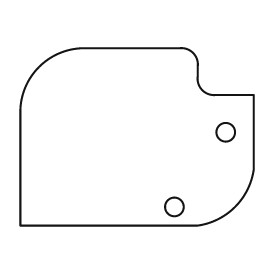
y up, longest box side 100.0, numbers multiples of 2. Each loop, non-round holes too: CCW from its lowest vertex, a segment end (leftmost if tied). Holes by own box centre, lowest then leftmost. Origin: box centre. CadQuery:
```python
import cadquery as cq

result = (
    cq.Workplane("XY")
    .moveTo(-50.0, -38.0)
    .lineTo(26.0, -38.0)
    .threePointArc((42.0, -30.0), (50.0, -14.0))
    .lineTo(50.0, 18.0)
    .lineTo(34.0, 18.0)
    .threePointArc((28.0, 20.0), (26.0, 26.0))
    .lineTo(26.0, 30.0)
    .threePointArc((24.0, 36.0), (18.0, 38.0))
    .lineTo(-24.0, 38.0)
    .threePointArc((-42.0, 30.0), (-50.0, 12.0))
    .close()
    .moveTo(16.0, -30.0)
    .circle(4.0)
    .moveTo(38.0, 2.0)
    .circle(4.0)
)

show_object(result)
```